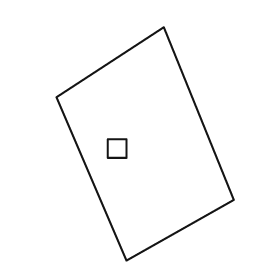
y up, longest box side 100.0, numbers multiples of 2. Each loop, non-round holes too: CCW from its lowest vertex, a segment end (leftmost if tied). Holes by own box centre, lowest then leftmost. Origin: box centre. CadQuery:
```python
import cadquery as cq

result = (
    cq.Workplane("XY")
    .moveTo(-8.0, -50.0)
    .lineTo(38.0, -24.0)
    .lineTo(8.0, 50.0)
    .lineTo(-38.0, 20.0)
    .close()
    .moveTo(-16.0, -6.0)
    .lineTo(-8.0, -6.0)
    .lineTo(-8.0, 2.0)
    .lineTo(-16.0, 2.0)
    .close()
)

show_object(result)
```